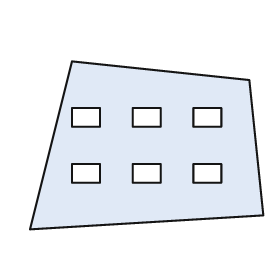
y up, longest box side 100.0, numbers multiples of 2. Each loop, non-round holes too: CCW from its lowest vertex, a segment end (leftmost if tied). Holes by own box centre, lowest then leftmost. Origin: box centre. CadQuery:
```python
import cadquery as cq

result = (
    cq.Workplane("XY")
    .moveTo(-50.0, -36.0)
    .lineTo(50.0, -30.0)
    .lineTo(44.0, 28.0)
    .lineTo(-32.0, 36.0)
    .close()
    .moveTo(-32.0, -16.0)
    .lineTo(-20.0, -16.0)
    .lineTo(-20.0, -8.0)
    .lineTo(-32.0, -8.0)
    .close()
    .moveTo(-6.0, -16.0)
    .lineTo(6.0, -16.0)
    .lineTo(6.0, -8.0)
    .lineTo(-6.0, -8.0)
    .close()
    .moveTo(20.0, -16.0)
    .lineTo(32.0, -16.0)
    .lineTo(32.0, -8.0)
    .lineTo(20.0, -8.0)
    .close()
    .moveTo(-32.0, 8.0)
    .lineTo(-20.0, 8.0)
    .lineTo(-20.0, 16.0)
    .lineTo(-32.0, 16.0)
    .close()
    .moveTo(-6.0, 8.0)
    .lineTo(6.0, 8.0)
    .lineTo(6.0, 16.0)
    .lineTo(-6.0, 16.0)
    .close()
    .moveTo(20.0, 8.0)
    .lineTo(32.0, 8.0)
    .lineTo(32.0, 16.0)
    .lineTo(20.0, 16.0)
    .close()
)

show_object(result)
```